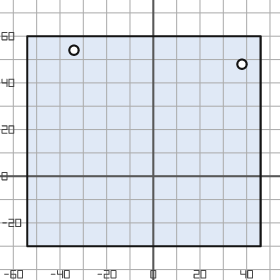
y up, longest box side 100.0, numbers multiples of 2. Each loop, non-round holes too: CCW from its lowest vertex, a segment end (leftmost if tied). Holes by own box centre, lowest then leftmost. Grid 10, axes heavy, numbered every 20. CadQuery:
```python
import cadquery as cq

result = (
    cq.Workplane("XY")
    .moveTo(-54.0, -30.0)
    .lineTo(46.0, -30.0)
    .lineTo(46.0, 60.0)
    .lineTo(-54.0, 60.0)
    .close()
    .moveTo(38.0, 48.0)
    .circle(2.0)
    .moveTo(-34.0, 54.0)
    .circle(2.0)
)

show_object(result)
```